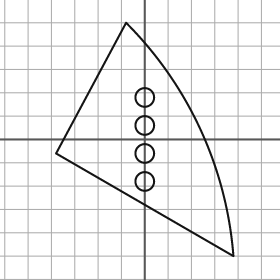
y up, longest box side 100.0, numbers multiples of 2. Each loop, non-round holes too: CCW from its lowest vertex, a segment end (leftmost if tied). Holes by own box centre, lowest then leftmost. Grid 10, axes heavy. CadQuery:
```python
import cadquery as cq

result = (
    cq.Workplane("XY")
    .moveTo(38.0, -50.0)
    .threePointArc((24.0, 4.0), (-8.0, 50.0))
    .lineTo(-38.0, -6.0)
    .close()
    .moveTo(0.0, -18.0)
    .circle(4.0)
    .moveTo(0.0, -6.0)
    .circle(4.0)
    .moveTo(0.0, 6.0)
    .circle(4.0)
    .moveTo(0.0, 18.0)
    .circle(4.0)
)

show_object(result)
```